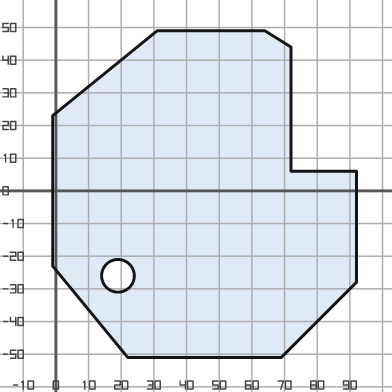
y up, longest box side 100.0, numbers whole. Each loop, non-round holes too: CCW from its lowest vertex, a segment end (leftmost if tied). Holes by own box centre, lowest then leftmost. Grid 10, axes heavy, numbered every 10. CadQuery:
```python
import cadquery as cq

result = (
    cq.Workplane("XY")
    .moveTo(22.0, -51.0)
    .lineTo(69.0, -51.0)
    .lineTo(92.0, -28.0)
    .lineTo(92.0, 6.0)
    .lineTo(72.0, 6.0)
    .lineTo(72.0, 44.0)
    .lineTo(64.0, 49.0)
    .lineTo(31.0, 49.0)
    .lineTo(-1.0, 23.0)
    .lineTo(-1.0, -23.0)
    .close()
    .moveTo(19.0, -26.0)
    .circle(5.0)
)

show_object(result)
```